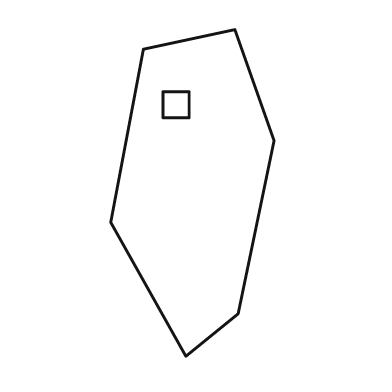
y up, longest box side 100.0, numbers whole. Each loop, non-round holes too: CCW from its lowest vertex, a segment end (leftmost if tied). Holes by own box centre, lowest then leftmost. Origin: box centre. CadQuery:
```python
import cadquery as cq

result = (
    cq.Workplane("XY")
    .moveTo(-2.0, -50.0)
    .lineTo(14.0, -37.0)
    .lineTo(25.0, 16.0)
    .lineTo(13.0, 50.0)
    .lineTo(-15.0, 44.0)
    .lineTo(-25.0, -9.0)
    .close()
    .moveTo(-9.0, 23.0)
    .lineTo(-1.0, 23.0)
    .lineTo(-1.0, 31.0)
    .lineTo(-9.0, 31.0)
    .close()
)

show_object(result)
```